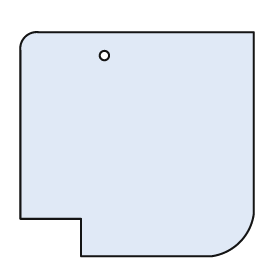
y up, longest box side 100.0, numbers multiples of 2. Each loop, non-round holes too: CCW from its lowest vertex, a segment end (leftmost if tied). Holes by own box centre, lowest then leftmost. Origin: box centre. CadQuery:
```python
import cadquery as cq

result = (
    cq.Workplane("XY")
    .moveTo(-24.0, -48.0)
    .lineTo(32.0, -48.0)
    .threePointArc((44.0, -42.0), (50.0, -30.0))
    .lineTo(50.0, 48.0)
    .lineTo(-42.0, 48.0)
    .threePointArc((-48.0, 46.0), (-50.0, 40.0))
    .lineTo(-50.0, -32.0)
    .lineTo(-24.0, -32.0)
    .close()
    .moveTo(-14.0, 38.0)
    .circle(2.0)
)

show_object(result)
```